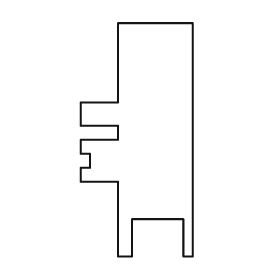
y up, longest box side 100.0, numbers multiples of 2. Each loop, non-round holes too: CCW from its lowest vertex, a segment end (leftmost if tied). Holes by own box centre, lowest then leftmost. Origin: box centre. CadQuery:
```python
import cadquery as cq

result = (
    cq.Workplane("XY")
    .moveTo(-8.0, -50.0)
    .lineTo(-2.0, -50.0)
    .lineTo(-2.0, -34.0)
    .lineTo(20.0, -34.0)
    .lineTo(20.0, -50.0)
    .lineTo(24.0, -50.0)
    .lineTo(24.0, 50.0)
    .lineTo(-8.0, 50.0)
    .lineTo(-8.0, 16.0)
    .lineTo(-24.0, 16.0)
    .lineTo(-24.0, 6.0)
    .lineTo(-8.0, 6.0)
    .lineTo(-8.0, 0.0)
    .lineTo(-24.0, 0.0)
    .lineTo(-24.0, -6.0)
    .lineTo(-20.0, -6.0)
    .lineTo(-20.0, -12.0)
    .lineTo(-24.0, -12.0)
    .lineTo(-24.0, -18.0)
    .lineTo(-8.0, -18.0)
    .close()
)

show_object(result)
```